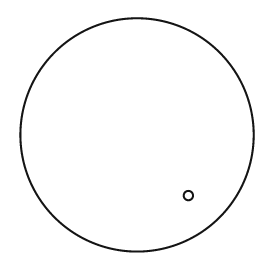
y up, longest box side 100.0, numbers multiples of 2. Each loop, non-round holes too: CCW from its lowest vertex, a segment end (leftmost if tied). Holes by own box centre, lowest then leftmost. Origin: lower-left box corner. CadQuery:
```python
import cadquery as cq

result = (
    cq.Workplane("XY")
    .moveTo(50.0, 50.0)
    .circle(50.0)
    .moveTo(72.0, 24.0)
    .circle(2.0)
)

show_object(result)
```